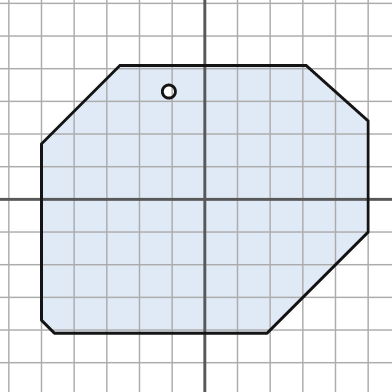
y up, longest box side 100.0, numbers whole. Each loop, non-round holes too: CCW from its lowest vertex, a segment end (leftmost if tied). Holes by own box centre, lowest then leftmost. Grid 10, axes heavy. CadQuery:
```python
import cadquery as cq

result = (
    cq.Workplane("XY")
    .moveTo(-46.0, -41.0)
    .lineTo(19.0, -41.0)
    .lineTo(50.0, -10.0)
    .lineTo(50.0, 24.0)
    .lineTo(31.0, 41.0)
    .lineTo(-26.0, 41.0)
    .lineTo(-50.0, 17.0)
    .lineTo(-50.0, -37.0)
    .close()
    .moveTo(-11.0, 33.0)
    .circle(2.0)
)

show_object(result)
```